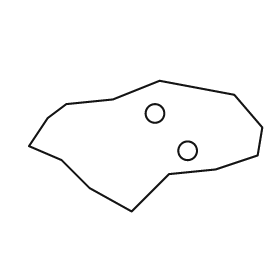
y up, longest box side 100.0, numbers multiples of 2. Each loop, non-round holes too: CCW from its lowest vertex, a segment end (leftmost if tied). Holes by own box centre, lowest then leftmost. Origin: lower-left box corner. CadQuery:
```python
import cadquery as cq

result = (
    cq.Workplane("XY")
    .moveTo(44.0, 0.0)
    .lineTo(60.0, 16.0)
    .lineTo(80.0, 18.0)
    .lineTo(98.0, 24.0)
    .lineTo(100.0, 36.0)
    .lineTo(88.0, 50.0)
    .lineTo(56.0, 56.0)
    .lineTo(36.0, 48.0)
    .lineTo(16.0, 46.0)
    .lineTo(8.0, 40.0)
    .lineTo(0.0, 28.0)
    .lineTo(14.0, 22.0)
    .lineTo(26.0, 10.0)
    .close()
    .moveTo(68.0, 26.0)
    .circle(4.0)
    .moveTo(54.0, 42.0)
    .circle(4.0)
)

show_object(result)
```